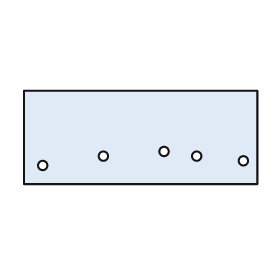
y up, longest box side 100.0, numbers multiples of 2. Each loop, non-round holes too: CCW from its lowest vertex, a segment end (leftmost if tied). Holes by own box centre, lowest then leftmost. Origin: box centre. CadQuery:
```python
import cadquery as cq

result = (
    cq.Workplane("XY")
    .moveTo(-50.0, -20.0)
    .lineTo(50.0, -20.0)
    .lineTo(50.0, 20.0)
    .lineTo(-50.0, 20.0)
    .close()
    .moveTo(-42.0, -12.0)
    .circle(2.0)
    .moveTo(44.0, -10.0)
    .circle(2.0)
    .moveTo(-16.0, -8.0)
    .circle(2.0)
    .moveTo(24.0, -8.0)
    .circle(2.0)
    .moveTo(10.0, -6.0)
    .circle(2.0)
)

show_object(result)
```